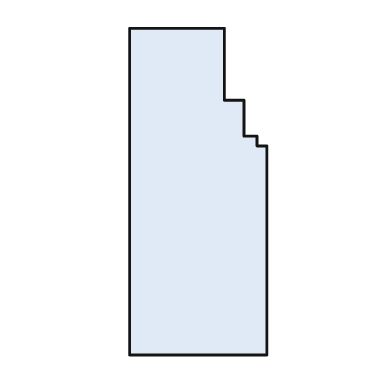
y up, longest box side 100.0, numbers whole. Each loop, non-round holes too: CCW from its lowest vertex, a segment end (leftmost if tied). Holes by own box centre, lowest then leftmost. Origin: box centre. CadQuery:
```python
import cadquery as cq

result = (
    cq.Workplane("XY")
    .moveTo(-21.0, -50.0)
    .lineTo(21.0, -50.0)
    .lineTo(21.0, 14.0)
    .lineTo(18.0, 14.0)
    .lineTo(18.0, 17.0)
    .lineTo(14.0, 17.0)
    .lineTo(14.0, 28.0)
    .lineTo(8.0, 28.0)
    .lineTo(8.0, 50.0)
    .lineTo(-21.0, 50.0)
    .close()
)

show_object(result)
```